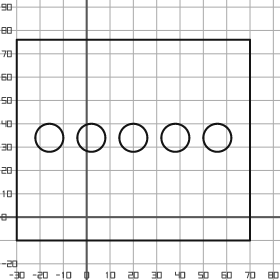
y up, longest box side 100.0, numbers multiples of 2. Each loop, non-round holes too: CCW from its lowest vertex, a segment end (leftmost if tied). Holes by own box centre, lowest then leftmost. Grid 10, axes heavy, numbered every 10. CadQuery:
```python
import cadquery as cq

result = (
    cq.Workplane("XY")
    .moveTo(-30.0, -10.0)
    .lineTo(70.0, -10.0)
    .lineTo(70.0, 76.0)
    .lineTo(-30.0, 76.0)
    .close()
    .moveTo(-16.0, 34.0)
    .circle(6.0)
    .moveTo(2.0, 34.0)
    .circle(6.0)
    .moveTo(20.0, 34.0)
    .circle(6.0)
    .moveTo(38.0, 34.0)
    .circle(6.0)
    .moveTo(56.0, 34.0)
    .circle(6.0)
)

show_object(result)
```